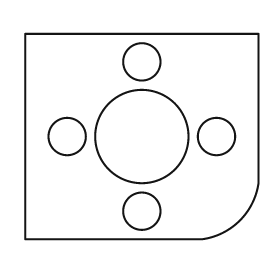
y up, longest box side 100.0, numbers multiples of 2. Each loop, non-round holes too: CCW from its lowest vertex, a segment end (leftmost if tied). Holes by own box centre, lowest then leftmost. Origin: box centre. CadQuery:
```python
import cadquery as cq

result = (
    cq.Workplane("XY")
    .moveTo(-50.0, -44.0)
    .lineTo(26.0, -44.0)
    .threePointArc((42.0, -36.0), (50.0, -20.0))
    .lineTo(50.0, 44.0)
    .lineTo(-50.0, 44.0)
    .close()
    .moveTo(0.0, -32.0)
    .circle(8.0)
    .moveTo(-32.0, 0.0)
    .circle(8.0)
    .moveTo(0.0, 0.0)
    .circle(20.0)
    .moveTo(32.0, 0.0)
    .circle(8.0)
    .moveTo(0.0, 32.0)
    .circle(8.0)
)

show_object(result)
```